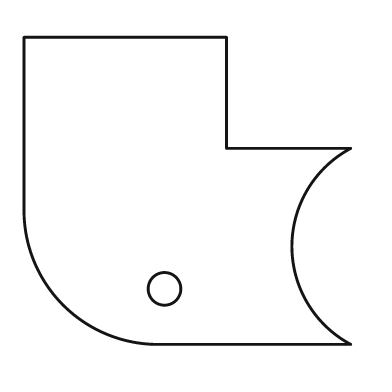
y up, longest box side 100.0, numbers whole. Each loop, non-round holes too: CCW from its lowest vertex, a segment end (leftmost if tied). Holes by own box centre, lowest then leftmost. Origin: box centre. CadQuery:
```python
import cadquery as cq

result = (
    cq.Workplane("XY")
    .moveTo(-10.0, -47.0)
    .lineTo(50.0, -47.0)
    .threePointArc((32.0, -17.0), (50.0, 13.0))
    .lineTo(12.0, 13.0)
    .lineTo(12.0, 47.0)
    .lineTo(-50.0, 47.0)
    .lineTo(-50.0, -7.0)
    .threePointArc((-38.0, -35.0), (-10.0, -47.0))
    .close()
    .moveTo(-7.0, -30.0)
    .circle(5.0)
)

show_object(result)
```